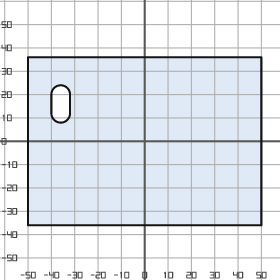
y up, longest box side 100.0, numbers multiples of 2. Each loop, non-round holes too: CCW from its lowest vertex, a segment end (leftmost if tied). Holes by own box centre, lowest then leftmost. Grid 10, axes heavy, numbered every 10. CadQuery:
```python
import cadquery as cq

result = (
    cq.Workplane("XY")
    .moveTo(-50.0, -36.0)
    .lineTo(50.0, -36.0)
    .lineTo(50.0, 36.0)
    .lineTo(-50.0, 36.0)
    .close()
    .moveTo(-40.0, 12.0)
    .threePointArc((-36.0, 8.0), (-32.0, 12.0))
    .lineTo(-32.0, 20.0)
    .threePointArc((-36.0, 24.0), (-40.0, 20.0))
    .close()
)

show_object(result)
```